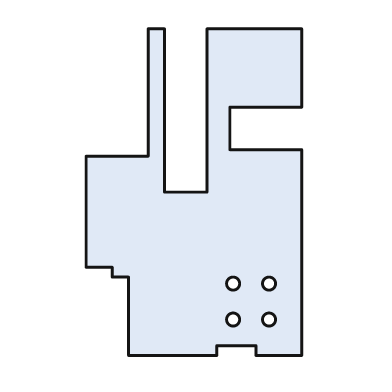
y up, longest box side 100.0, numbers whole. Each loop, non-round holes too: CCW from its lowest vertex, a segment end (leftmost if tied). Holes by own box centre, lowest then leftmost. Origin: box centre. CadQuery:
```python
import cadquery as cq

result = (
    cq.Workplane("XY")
    .moveTo(-20.0, -50.0)
    .lineTo(7.0, -50.0)
    .lineTo(7.0, -47.0)
    .lineTo(19.0, -47.0)
    .lineTo(19.0, -50.0)
    .lineTo(33.0, -50.0)
    .lineTo(33.0, 13.0)
    .lineTo(11.0, 13.0)
    .lineTo(11.0, 26.0)
    .lineTo(33.0, 26.0)
    .lineTo(33.0, 50.0)
    .lineTo(4.0, 50.0)
    .lineTo(4.0, 0.0)
    .lineTo(-9.0, 0.0)
    .lineTo(-9.0, 50.0)
    .lineTo(-14.0, 50.0)
    .lineTo(-14.0, 11.0)
    .lineTo(-33.0, 11.0)
    .lineTo(-33.0, -23.0)
    .lineTo(-25.0, -23.0)
    .lineTo(-25.0, -26.0)
    .lineTo(-20.0, -26.0)
    .close()
    .moveTo(12.0, -39.0)
    .circle(2.0)
    .moveTo(23.0, -39.0)
    .circle(2.0)
    .moveTo(12.0, -28.0)
    .circle(2.0)
    .moveTo(23.0, -28.0)
    .circle(2.0)
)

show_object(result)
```